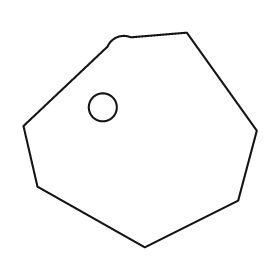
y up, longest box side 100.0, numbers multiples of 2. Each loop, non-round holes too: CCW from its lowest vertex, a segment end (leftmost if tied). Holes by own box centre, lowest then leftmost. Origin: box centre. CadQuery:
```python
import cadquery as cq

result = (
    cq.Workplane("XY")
    .moveTo(2.0, -46.0)
    .lineTo(42.0, -26.0)
    .lineTo(50.0, 4.0)
    .lineTo(20.0, 46.0)
    .lineTo(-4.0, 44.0)
    .threePointArc((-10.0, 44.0), (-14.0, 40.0))
    .lineTo(-50.0, 6.0)
    .lineTo(-44.0, -20.0)
    .close()
    .moveTo(-16.0, 14.0)
    .circle(6.0)
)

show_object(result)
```